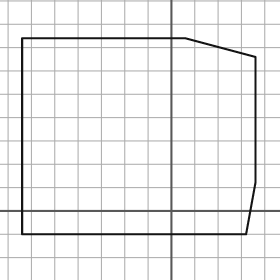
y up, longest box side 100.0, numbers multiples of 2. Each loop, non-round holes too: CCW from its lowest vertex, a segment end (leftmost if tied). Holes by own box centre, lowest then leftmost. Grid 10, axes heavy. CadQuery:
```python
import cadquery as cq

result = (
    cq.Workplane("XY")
    .moveTo(-64.0, -10.0)
    .lineTo(32.0, -10.0)
    .lineTo(36.0, 12.0)
    .lineTo(36.0, 66.0)
    .lineTo(6.0, 74.0)
    .lineTo(-64.0, 74.0)
    .close()
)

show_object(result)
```